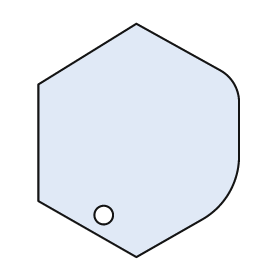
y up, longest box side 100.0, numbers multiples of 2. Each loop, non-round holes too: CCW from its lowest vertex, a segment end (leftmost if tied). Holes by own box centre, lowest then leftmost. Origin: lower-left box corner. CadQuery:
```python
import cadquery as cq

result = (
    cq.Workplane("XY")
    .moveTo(42.0, 0.0)
    .lineTo(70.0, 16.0)
    .threePointArc((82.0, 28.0), (86.0, 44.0))
    .lineTo(86.0, 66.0)
    .threePointArc((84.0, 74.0), (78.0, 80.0))
    .lineTo(42.0, 100.0)
    .lineTo(0.0, 74.0)
    .lineTo(0.0, 24.0)
    .close()
    .moveTo(28.0, 18.0)
    .circle(4.0)
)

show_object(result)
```